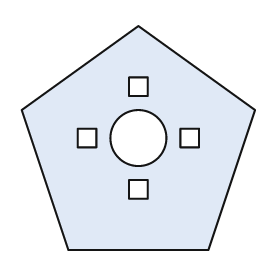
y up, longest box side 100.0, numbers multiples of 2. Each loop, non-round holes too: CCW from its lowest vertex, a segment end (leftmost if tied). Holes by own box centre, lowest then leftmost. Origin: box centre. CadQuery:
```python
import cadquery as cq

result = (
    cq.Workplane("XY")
    .moveTo(-30.0, -48.0)
    .lineTo(30.0, -48.0)
    .lineTo(50.0, 12.0)
    .lineTo(0.0, 48.0)
    .lineTo(-50.0, 12.0)
    .close()
    .moveTo(-4.0, -26.0)
    .lineTo(4.0, -26.0)
    .lineTo(4.0, -18.0)
    .lineTo(-4.0, -18.0)
    .close()
    .moveTo(-26.0, -4.0)
    .lineTo(-18.0, -4.0)
    .lineTo(-18.0, 4.0)
    .lineTo(-26.0, 4.0)
    .close()
    .moveTo(0.0, 0.0)
    .circle(12.0)
    .moveTo(18.0, -4.0)
    .lineTo(26.0, -4.0)
    .lineTo(26.0, 4.0)
    .lineTo(18.0, 4.0)
    .close()
    .moveTo(-4.0, 18.0)
    .lineTo(4.0, 18.0)
    .lineTo(4.0, 26.0)
    .lineTo(-4.0, 26.0)
    .close()
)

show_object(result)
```